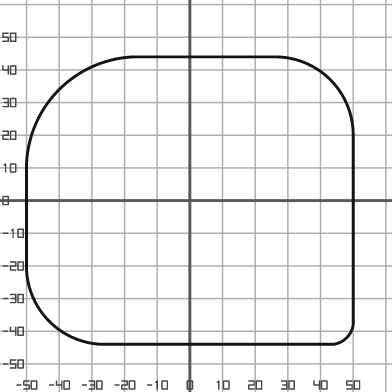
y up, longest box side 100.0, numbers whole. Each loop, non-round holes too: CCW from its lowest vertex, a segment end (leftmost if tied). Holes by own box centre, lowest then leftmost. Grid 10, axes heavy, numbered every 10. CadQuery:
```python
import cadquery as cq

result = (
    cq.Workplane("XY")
    .moveTo(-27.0, -44.0)
    .lineTo(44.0, -44.0)
    .threePointArc((48.0, -42.0), (50.0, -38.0))
    .lineTo(50.0, 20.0)
    .threePointArc((43.0, 37.0), (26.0, 44.0))
    .lineTo(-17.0, 44.0)
    .threePointArc((-40.0, 34.0), (-50.0, 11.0))
    .lineTo(-50.0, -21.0)
    .threePointArc((-43.0, -37.0), (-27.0, -44.0))
    .close()
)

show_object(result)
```